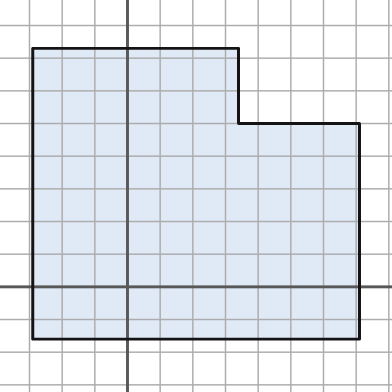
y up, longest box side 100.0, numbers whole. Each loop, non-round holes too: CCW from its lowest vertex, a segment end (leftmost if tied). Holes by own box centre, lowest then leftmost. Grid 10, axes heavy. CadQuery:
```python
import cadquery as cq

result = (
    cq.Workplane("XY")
    .moveTo(-29.0, -16.0)
    .lineTo(71.0, -16.0)
    .lineTo(71.0, 50.0)
    .lineTo(34.0, 50.0)
    .lineTo(34.0, 73.0)
    .lineTo(-29.0, 73.0)
    .close()
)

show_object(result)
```